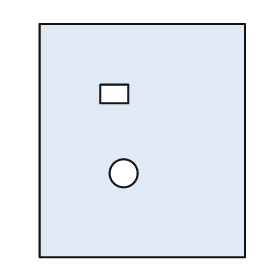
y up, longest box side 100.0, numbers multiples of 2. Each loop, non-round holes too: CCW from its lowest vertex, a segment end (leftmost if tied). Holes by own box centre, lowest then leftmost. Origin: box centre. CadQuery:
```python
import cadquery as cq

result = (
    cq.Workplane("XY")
    .moveTo(-44.0, -50.0)
    .lineTo(44.0, -50.0)
    .lineTo(44.0, 50.0)
    .lineTo(-44.0, 50.0)
    .close()
    .moveTo(-8.0, -14.0)
    .circle(6.0)
    .moveTo(-18.0, 16.0)
    .lineTo(-6.0, 16.0)
    .lineTo(-6.0, 24.0)
    .lineTo(-18.0, 24.0)
    .close()
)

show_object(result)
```